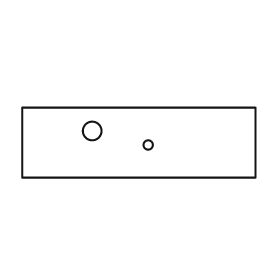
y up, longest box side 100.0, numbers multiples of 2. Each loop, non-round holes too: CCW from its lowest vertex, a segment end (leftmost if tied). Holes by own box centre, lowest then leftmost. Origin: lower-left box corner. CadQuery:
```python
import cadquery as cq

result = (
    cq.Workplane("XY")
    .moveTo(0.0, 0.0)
    .lineTo(100.0, 0.0)
    .lineTo(100.0, 30.0)
    .lineTo(0.0, 30.0)
    .close()
    .moveTo(54.0, 14.0)
    .circle(2.0)
    .moveTo(30.0, 20.0)
    .circle(4.0)
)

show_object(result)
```